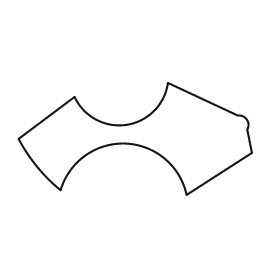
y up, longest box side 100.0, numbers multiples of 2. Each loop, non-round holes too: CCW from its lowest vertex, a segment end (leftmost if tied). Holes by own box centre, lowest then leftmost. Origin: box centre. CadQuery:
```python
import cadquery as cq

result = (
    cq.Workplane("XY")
    .moveTo(22.0, -24.0)
    .lineTo(50.0, -6.0)
    .lineTo(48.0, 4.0)
    .threePointArc((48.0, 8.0), (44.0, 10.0))
    .lineTo(14.0, 24.0)
    .threePointArc((-4.0, 6.0), (-26.0, 18.0))
    .lineTo(-50.0, 0.0)
    .threePointArc((-42.0, -12.0), (-32.0, -22.0))
    .threePointArc((-4.0, -2.0), (22.0, -24.0))
    .close()
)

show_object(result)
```